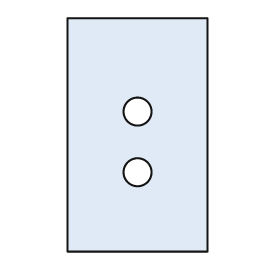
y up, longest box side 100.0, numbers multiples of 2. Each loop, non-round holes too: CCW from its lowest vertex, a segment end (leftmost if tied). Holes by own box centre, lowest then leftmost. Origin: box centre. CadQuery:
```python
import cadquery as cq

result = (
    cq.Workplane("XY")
    .moveTo(-30.0, -50.0)
    .lineTo(30.0, -50.0)
    .lineTo(30.0, 50.0)
    .lineTo(-30.0, 50.0)
    .close()
    .moveTo(0.0, -16.0)
    .circle(6.0)
    .moveTo(0.0, 10.0)
    .circle(6.0)
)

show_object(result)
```